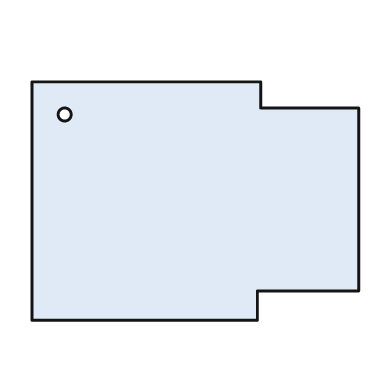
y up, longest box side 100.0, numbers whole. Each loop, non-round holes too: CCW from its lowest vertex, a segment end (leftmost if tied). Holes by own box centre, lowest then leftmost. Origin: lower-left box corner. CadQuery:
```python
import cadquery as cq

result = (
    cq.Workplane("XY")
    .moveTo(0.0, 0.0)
    .lineTo(69.0, 0.0)
    .lineTo(69.0, 9.0)
    .lineTo(100.0, 9.0)
    .lineTo(100.0, 65.0)
    .lineTo(70.0, 65.0)
    .lineTo(70.0, 73.0)
    .lineTo(0.0, 73.0)
    .close()
    .moveTo(10.0, 63.0)
    .circle(2.0)
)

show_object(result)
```